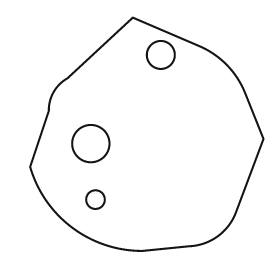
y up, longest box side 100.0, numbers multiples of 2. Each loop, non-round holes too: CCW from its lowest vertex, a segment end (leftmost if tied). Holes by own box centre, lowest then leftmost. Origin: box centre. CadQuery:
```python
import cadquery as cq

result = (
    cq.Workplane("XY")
    .moveTo(-2.0, -50.0)
    .lineTo(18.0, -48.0)
    .threePointArc((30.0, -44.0), (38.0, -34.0))
    .lineTo(50.0, -2.0)
    .lineTo(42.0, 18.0)
    .threePointArc((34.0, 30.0), (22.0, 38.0))
    .lineTo(-6.0, 50.0)
    .lineTo(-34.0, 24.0)
    .threePointArc((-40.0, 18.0), (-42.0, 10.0))
    .lineTo(-50.0, -14.0)
    .threePointArc((-32.0, -40.0), (-2.0, -50.0))
    .close()
    .moveTo(-22.0, -28.0)
    .circle(4.0)
    .moveTo(-24.0, -4.0)
    .circle(8.0)
    .moveTo(6.0, 34.0)
    .circle(6.0)
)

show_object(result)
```